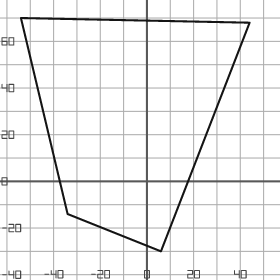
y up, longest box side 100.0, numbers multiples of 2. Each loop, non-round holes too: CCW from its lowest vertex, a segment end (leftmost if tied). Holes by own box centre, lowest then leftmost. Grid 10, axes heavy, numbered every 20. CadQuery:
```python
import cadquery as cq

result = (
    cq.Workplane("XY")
    .moveTo(6.0, -30.0)
    .lineTo(44.0, 68.0)
    .lineTo(-54.0, 70.0)
    .lineTo(-34.0, -14.0)
    .close()
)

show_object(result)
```